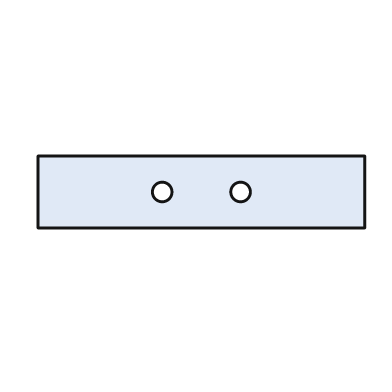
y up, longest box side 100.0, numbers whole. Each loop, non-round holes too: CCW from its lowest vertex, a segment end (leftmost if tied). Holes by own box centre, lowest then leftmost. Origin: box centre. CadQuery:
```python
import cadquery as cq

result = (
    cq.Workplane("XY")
    .moveTo(-50.0, -11.0)
    .lineTo(50.0, -11.0)
    .lineTo(50.0, 11.0)
    .lineTo(-50.0, 11.0)
    .close()
    .moveTo(-12.0, 0.0)
    .circle(3.0)
    .moveTo(12.0, 0.0)
    .circle(3.0)
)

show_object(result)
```